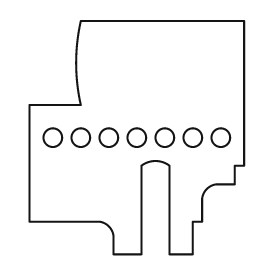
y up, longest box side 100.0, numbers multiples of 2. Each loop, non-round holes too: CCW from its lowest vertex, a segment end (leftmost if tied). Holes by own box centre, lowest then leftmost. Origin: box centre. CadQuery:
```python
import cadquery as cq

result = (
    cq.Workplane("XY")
    .moveTo(-10.0, -50.0)
    .lineTo(2.0, -50.0)
    .lineTo(2.0, -12.0)
    .threePointArc((8.0, -10.0), (14.0, -12.0))
    .lineTo(14.0, -50.0)
    .lineTo(24.0, -50.0)
    .lineTo(24.0, -36.0)
    .lineTo(28.0, -36.0)
    .lineTo(28.0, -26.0)
    .threePointArc((30.0, -22.0), (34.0, -20.0))
    .lineTo(42.0, -20.0)
    .lineTo(42.0, -12.0)
    .lineTo(46.0, -12.0)
    .lineTo(46.0, 50.0)
    .lineTo(-24.0, 50.0)
    .threePointArc((-26.0, 32.0), (-24.0, 14.0))
    .lineTo(-46.0, 14.0)
    .lineTo(-46.0, -36.0)
    .lineTo(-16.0, -36.0)
    .threePointArc((-12.0, -38.0), (-10.0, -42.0))
    .close()
    .moveTo(-36.0, 0.0)
    .circle(4.0)
    .moveTo(-24.0, 0.0)
    .circle(4.0)
    .moveTo(-12.0, 0.0)
    .circle(4.0)
    .moveTo(0.0, 0.0)
    .circle(4.0)
    .moveTo(12.0, 0.0)
    .circle(4.0)
    .moveTo(24.0, 0.0)
    .circle(4.0)
    .moveTo(36.0, 0.0)
    .circle(4.0)
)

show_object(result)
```